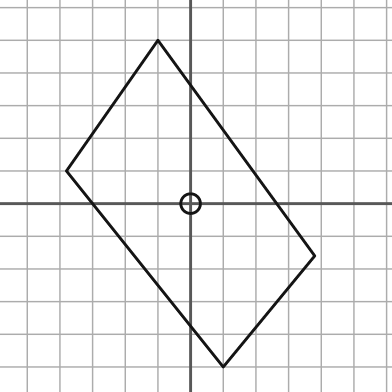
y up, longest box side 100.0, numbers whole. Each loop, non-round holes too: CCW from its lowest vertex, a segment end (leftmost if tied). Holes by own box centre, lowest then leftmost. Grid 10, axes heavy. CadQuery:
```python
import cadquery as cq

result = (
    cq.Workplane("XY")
    .moveTo(10.0, -50.0)
    .lineTo(38.0, -16.0)
    .lineTo(-10.0, 50.0)
    .lineTo(-38.0, 10.0)
    .close()
    .moveTo(0.0, 0.0)
    .circle(3.0)
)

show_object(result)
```